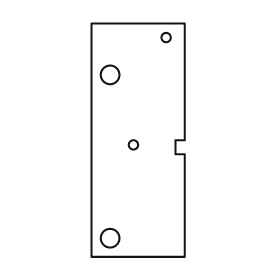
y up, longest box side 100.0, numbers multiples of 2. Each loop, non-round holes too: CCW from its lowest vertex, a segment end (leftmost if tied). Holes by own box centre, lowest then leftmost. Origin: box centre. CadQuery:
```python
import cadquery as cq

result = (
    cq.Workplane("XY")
    .moveTo(-20.0, -50.0)
    .lineTo(20.0, -50.0)
    .lineTo(20.0, -6.0)
    .lineTo(16.0, -6.0)
    .lineTo(16.0, 0.0)
    .lineTo(20.0, 0.0)
    .lineTo(20.0, 50.0)
    .lineTo(-20.0, 50.0)
    .close()
    .moveTo(-12.0, -42.0)
    .circle(4.0)
    .moveTo(-2.0, -2.0)
    .circle(2.0)
    .moveTo(-12.0, 28.0)
    .circle(4.0)
    .moveTo(12.0, 44.0)
    .circle(2.0)
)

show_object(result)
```